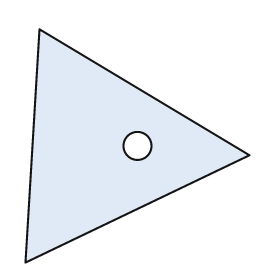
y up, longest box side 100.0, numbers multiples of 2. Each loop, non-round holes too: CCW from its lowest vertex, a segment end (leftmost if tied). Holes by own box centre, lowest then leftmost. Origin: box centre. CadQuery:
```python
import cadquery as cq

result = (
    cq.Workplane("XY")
    .moveTo(-48.0, -50.0)
    .lineTo(48.0, -4.0)
    .lineTo(-42.0, 50.0)
    .close()
    .moveTo(0.0, 0.0)
    .circle(6.0)
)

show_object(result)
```